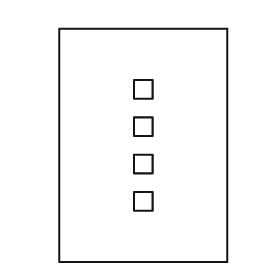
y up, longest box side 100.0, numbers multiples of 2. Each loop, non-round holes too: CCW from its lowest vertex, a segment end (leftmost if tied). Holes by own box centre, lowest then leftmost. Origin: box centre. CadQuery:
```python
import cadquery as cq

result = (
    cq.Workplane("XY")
    .moveTo(-36.0, -50.0)
    .lineTo(36.0, -50.0)
    .lineTo(36.0, 50.0)
    .lineTo(-36.0, 50.0)
    .close()
    .moveTo(-4.0, -28.0)
    .lineTo(4.0, -28.0)
    .lineTo(4.0, -20.0)
    .lineTo(-4.0, -20.0)
    .close()
    .moveTo(-4.0, -12.0)
    .lineTo(4.0, -12.0)
    .lineTo(4.0, -4.0)
    .lineTo(-4.0, -4.0)
    .close()
    .moveTo(-4.0, 4.0)
    .lineTo(4.0, 4.0)
    .lineTo(4.0, 12.0)
    .lineTo(-4.0, 12.0)
    .close()
    .moveTo(-4.0, 20.0)
    .lineTo(4.0, 20.0)
    .lineTo(4.0, 28.0)
    .lineTo(-4.0, 28.0)
    .close()
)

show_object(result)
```